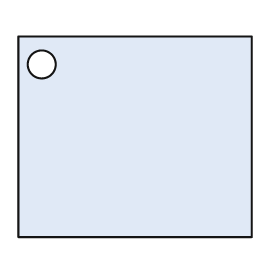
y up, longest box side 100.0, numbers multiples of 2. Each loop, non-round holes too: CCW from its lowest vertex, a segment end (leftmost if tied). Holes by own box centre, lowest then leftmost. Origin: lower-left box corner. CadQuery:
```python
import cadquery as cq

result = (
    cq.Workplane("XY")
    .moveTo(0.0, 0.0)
    .lineTo(100.0, 0.0)
    .lineTo(100.0, 86.0)
    .lineTo(0.0, 86.0)
    .close()
    .moveTo(10.0, 74.0)
    .circle(6.0)
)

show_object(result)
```